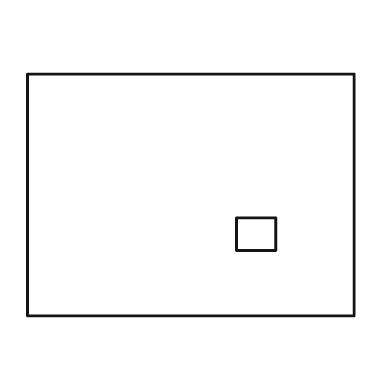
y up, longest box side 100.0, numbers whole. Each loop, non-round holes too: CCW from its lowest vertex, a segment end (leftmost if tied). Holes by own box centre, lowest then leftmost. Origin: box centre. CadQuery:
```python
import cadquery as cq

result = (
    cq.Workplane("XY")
    .moveTo(-50.0, -37.0)
    .lineTo(50.0, -37.0)
    .lineTo(50.0, 37.0)
    .lineTo(-50.0, 37.0)
    .close()
    .moveTo(14.0, -17.0)
    .lineTo(26.0, -17.0)
    .lineTo(26.0, -7.0)
    .lineTo(14.0, -7.0)
    .close()
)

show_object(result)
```